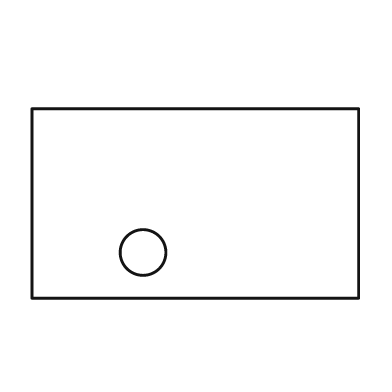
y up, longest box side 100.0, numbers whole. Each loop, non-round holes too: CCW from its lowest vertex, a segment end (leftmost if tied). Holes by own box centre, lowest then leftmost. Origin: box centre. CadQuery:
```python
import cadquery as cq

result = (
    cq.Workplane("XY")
    .moveTo(-50.0, -29.0)
    .lineTo(50.0, -29.0)
    .lineTo(50.0, 29.0)
    .lineTo(-50.0, 29.0)
    .close()
    .moveTo(-16.0, -15.0)
    .circle(7.0)
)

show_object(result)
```